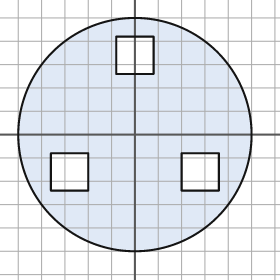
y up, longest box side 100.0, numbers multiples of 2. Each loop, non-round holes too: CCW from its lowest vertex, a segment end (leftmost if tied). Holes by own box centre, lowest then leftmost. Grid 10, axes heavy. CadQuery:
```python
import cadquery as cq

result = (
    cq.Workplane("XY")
    .moveTo(0.0, 0.0)
    .circle(50.0)
    .moveTo(-36.0, -24.0)
    .lineTo(-20.0, -24.0)
    .lineTo(-20.0, -8.0)
    .lineTo(-36.0, -8.0)
    .close()
    .moveTo(20.0, -24.0)
    .lineTo(36.0, -24.0)
    .lineTo(36.0, -8.0)
    .lineTo(20.0, -8.0)
    .close()
    .moveTo(-8.0, 26.0)
    .lineTo(8.0, 26.0)
    .lineTo(8.0, 42.0)
    .lineTo(-8.0, 42.0)
    .close()
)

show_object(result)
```